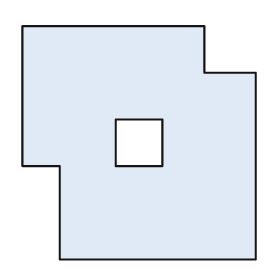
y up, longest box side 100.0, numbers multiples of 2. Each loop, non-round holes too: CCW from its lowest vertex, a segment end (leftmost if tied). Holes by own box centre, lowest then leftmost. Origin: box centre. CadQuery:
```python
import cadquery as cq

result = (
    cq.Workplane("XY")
    .moveTo(-34.0, -50.0)
    .lineTo(50.0, -50.0)
    .lineTo(50.0, 30.0)
    .lineTo(28.0, 30.0)
    .lineTo(28.0, 50.0)
    .lineTo(-50.0, 50.0)
    .lineTo(-50.0, -10.0)
    .lineTo(-34.0, -10.0)
    .close()
    .moveTo(-10.0, -10.0)
    .lineTo(10.0, -10.0)
    .lineTo(10.0, 10.0)
    .lineTo(-10.0, 10.0)
    .close()
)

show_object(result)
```